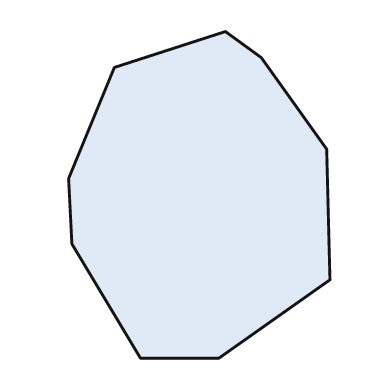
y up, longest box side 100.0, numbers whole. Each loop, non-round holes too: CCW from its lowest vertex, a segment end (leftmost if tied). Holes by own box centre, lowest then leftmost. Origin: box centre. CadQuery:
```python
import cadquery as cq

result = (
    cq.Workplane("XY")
    .moveTo(-18.0, -50.0)
    .lineTo(6.0, -50.0)
    .lineTo(40.0, -26.0)
    .lineTo(39.0, 14.0)
    .lineTo(19.0, 42.0)
    .lineTo(8.0, 50.0)
    .lineTo(-26.0, 39.0)
    .lineTo(-40.0, 5.0)
    .lineTo(-39.0, -15.0)
    .close()
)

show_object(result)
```